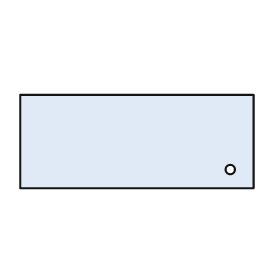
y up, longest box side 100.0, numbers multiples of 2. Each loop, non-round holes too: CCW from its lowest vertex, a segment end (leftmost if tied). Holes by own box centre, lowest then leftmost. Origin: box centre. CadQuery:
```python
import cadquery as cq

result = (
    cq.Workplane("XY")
    .moveTo(-50.0, -20.0)
    .lineTo(50.0, -20.0)
    .lineTo(50.0, 20.0)
    .lineTo(-50.0, 20.0)
    .close()
    .moveTo(40.0, -12.0)
    .circle(2.0)
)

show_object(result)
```